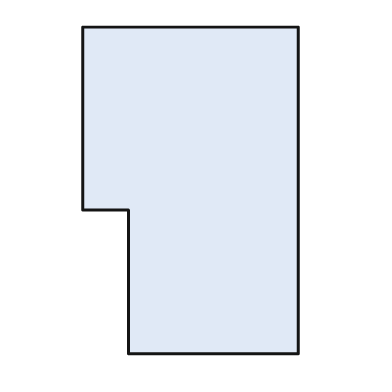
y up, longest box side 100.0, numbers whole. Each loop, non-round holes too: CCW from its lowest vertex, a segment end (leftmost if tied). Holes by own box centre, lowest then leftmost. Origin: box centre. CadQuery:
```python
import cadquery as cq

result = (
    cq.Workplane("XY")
    .moveTo(-19.0, -50.0)
    .lineTo(33.0, -50.0)
    .lineTo(33.0, 50.0)
    .lineTo(-33.0, 50.0)
    .lineTo(-33.0, -6.0)
    .lineTo(-19.0, -6.0)
    .close()
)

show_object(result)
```